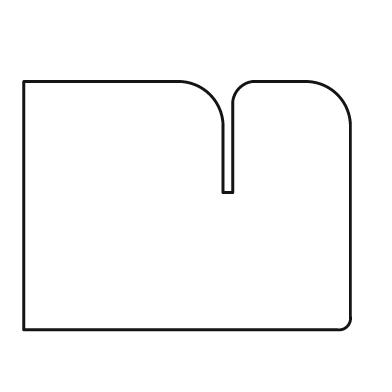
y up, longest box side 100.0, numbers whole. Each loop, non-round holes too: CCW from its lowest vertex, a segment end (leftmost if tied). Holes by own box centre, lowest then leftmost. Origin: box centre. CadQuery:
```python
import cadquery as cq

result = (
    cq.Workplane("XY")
    .moveTo(-50.0, -38.0)
    .lineTo(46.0, -38.0)
    .threePointArc((49.0, -37.0), (50.0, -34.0))
    .lineTo(50.0, 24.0)
    .threePointArc((46.0, 34.0), (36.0, 38.0))
    .lineTo(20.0, 38.0)
    .threePointArc((16.0, 36.0), (14.0, 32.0))
    .lineTo(14.0, 4.0)
    .lineTo(11.0, 4.0)
    .lineTo(11.0, 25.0)
    .threePointArc((7.0, 34.0), (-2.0, 38.0))
    .lineTo(-50.0, 38.0)
    .close()
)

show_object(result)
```